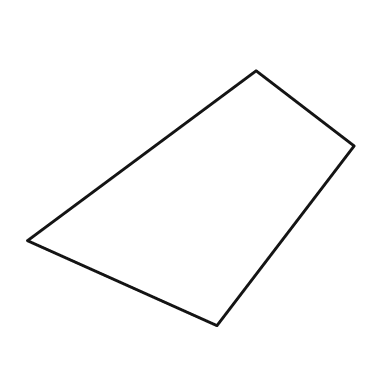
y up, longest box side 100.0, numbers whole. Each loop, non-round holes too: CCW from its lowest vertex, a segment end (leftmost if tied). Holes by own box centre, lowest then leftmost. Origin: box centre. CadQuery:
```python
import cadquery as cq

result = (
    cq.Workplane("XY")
    .moveTo(8.0, -39.0)
    .lineTo(50.0, 16.0)
    .lineTo(20.0, 39.0)
    .lineTo(-50.0, -13.0)
    .close()
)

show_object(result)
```